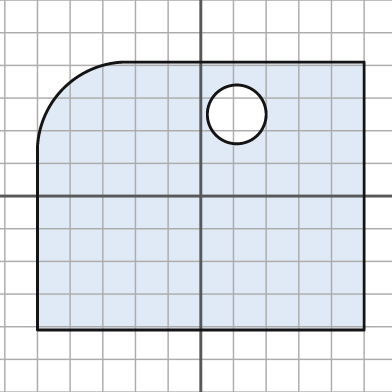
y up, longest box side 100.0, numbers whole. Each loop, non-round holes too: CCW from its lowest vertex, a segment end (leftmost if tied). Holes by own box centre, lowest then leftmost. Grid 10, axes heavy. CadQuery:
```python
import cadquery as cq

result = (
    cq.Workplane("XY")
    .moveTo(-50.0, -41.0)
    .lineTo(50.0, -41.0)
    .lineTo(50.0, 41.0)
    .lineTo(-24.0, 41.0)
    .threePointArc((-42.0, 33.0), (-50.0, 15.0))
    .close()
    .moveTo(11.0, 25.0)
    .circle(9.0)
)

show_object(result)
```